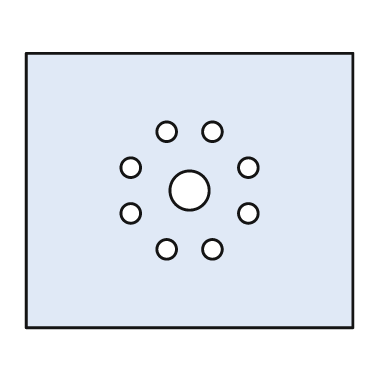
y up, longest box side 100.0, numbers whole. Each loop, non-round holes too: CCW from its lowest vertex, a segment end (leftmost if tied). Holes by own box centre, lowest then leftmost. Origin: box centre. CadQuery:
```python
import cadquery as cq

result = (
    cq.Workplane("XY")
    .moveTo(-50.0, -42.0)
    .lineTo(50.0, -42.0)
    .lineTo(50.0, 42.0)
    .lineTo(-50.0, 42.0)
    .close()
    .moveTo(-7.0, -18.0)
    .circle(3.0)
    .moveTo(7.0, -18.0)
    .circle(3.0)
    .moveTo(-18.0, -7.0)
    .circle(3.0)
    .moveTo(18.0, -7.0)
    .circle(3.0)
    .moveTo(0.0, 0.0)
    .circle(6.0)
    .moveTo(-18.0, 7.0)
    .circle(3.0)
    .moveTo(18.0, 7.0)
    .circle(3.0)
    .moveTo(-7.0, 18.0)
    .circle(3.0)
    .moveTo(7.0, 18.0)
    .circle(3.0)
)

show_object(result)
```